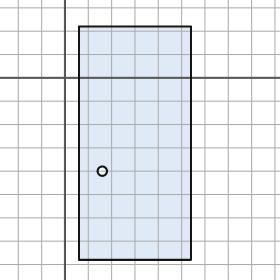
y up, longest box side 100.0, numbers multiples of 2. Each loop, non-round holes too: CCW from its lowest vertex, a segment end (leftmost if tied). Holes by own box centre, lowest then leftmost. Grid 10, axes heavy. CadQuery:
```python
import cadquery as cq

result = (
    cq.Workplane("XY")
    .moveTo(6.0, -78.0)
    .lineTo(54.0, -78.0)
    .lineTo(54.0, 22.0)
    .lineTo(6.0, 22.0)
    .close()
    .moveTo(16.0, -40.0)
    .circle(2.0)
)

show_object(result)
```